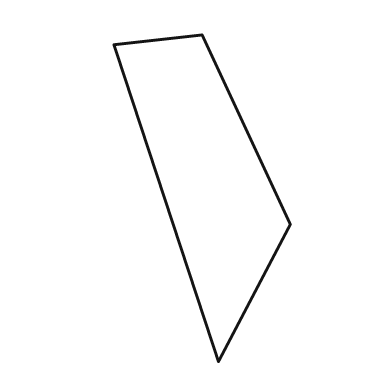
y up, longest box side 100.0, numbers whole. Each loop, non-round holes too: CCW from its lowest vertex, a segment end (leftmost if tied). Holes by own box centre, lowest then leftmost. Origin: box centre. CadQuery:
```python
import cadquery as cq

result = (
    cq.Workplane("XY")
    .moveTo(5.0, -50.0)
    .lineTo(27.0, -8.0)
    .lineTo(0.0, 50.0)
    .lineTo(-27.0, 47.0)
    .close()
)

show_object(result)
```